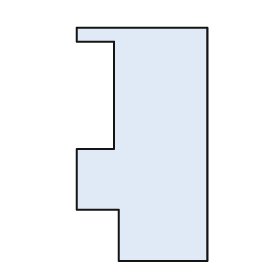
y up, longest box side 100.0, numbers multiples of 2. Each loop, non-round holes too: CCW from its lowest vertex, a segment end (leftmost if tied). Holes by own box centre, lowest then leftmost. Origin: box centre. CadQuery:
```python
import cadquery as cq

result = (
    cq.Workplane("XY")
    .moveTo(-10.0, -50.0)
    .lineTo(28.0, -50.0)
    .lineTo(28.0, 50.0)
    .lineTo(-28.0, 50.0)
    .lineTo(-28.0, 44.0)
    .lineTo(-12.0, 44.0)
    .lineTo(-12.0, -2.0)
    .lineTo(-28.0, -2.0)
    .lineTo(-28.0, -28.0)
    .lineTo(-10.0, -28.0)
    .close()
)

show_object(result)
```